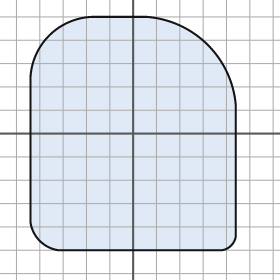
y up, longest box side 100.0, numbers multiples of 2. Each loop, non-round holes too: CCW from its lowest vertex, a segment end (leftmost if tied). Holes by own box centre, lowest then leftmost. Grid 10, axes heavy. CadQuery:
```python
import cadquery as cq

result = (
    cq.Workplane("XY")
    .moveTo(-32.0, -50.0)
    .lineTo(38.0, -50.0)
    .threePointArc((42.0, -48.0), (44.0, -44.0))
    .lineTo(44.0, 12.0)
    .threePointArc((32.0, 38.0), (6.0, 50.0))
    .lineTo(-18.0, 50.0)
    .threePointArc((-36.0, 42.0), (-44.0, 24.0))
    .lineTo(-44.0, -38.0)
    .threePointArc((-40.0, -46.0), (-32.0, -50.0))
    .close()
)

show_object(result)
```